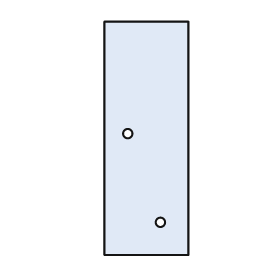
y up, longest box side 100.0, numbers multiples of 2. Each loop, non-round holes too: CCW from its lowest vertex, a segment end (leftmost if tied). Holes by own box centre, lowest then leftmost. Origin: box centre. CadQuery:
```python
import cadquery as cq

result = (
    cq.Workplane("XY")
    .moveTo(-18.0, -50.0)
    .lineTo(18.0, -50.0)
    .lineTo(18.0, 50.0)
    .lineTo(-18.0, 50.0)
    .close()
    .moveTo(6.0, -36.0)
    .circle(2.0)
    .moveTo(-8.0, 2.0)
    .circle(2.0)
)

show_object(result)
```